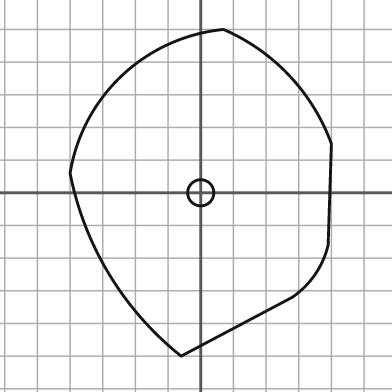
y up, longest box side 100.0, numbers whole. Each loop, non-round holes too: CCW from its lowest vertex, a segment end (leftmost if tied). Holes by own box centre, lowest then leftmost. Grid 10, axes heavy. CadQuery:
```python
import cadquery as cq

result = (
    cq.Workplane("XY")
    .moveTo(-6.0, -50.0)
    .lineTo(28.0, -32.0)
    .threePointArc((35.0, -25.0), (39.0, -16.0))
    .lineTo(40.0, 15.0)
    .threePointArc((27.0, 36.0), (7.0, 50.0))
    .threePointArc((-24.0, 36.0), (-40.0, 6.0))
    .threePointArc((-28.0, -25.0), (-6.0, -50.0))
    .close()
    .moveTo(0.0, 0.0)
    .circle(4.0)
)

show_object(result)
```